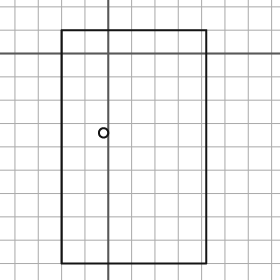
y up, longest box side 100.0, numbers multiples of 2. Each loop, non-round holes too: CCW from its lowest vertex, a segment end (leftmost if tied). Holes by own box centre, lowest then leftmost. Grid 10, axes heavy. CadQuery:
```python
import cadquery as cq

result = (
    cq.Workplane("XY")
    .moveTo(-20.0, -90.0)
    .lineTo(42.0, -90.0)
    .lineTo(42.0, 10.0)
    .lineTo(-20.0, 10.0)
    .close()
    .moveTo(-2.0, -34.0)
    .circle(2.0)
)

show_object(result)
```